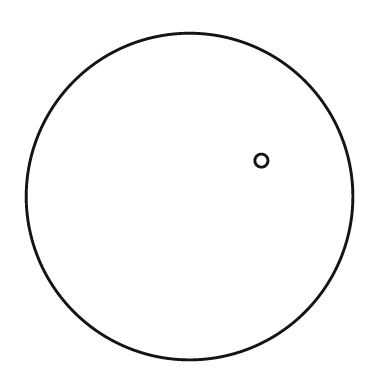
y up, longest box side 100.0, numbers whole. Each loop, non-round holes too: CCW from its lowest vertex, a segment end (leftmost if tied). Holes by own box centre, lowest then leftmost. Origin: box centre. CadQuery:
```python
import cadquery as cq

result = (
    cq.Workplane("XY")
    .moveTo(0.0, 0.0)
    .circle(50.0)
    .moveTo(22.0, 11.0)
    .circle(2.0)
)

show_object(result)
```